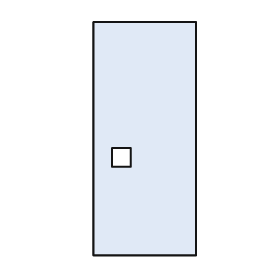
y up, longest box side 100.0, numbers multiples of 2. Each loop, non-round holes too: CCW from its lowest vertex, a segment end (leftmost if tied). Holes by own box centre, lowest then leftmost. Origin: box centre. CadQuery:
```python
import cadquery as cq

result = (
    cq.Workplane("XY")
    .moveTo(-22.0, -50.0)
    .lineTo(22.0, -50.0)
    .lineTo(22.0, 50.0)
    .lineTo(-22.0, 50.0)
    .close()
    .moveTo(-14.0, -12.0)
    .lineTo(-6.0, -12.0)
    .lineTo(-6.0, -4.0)
    .lineTo(-14.0, -4.0)
    .close()
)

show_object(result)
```